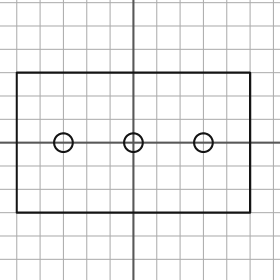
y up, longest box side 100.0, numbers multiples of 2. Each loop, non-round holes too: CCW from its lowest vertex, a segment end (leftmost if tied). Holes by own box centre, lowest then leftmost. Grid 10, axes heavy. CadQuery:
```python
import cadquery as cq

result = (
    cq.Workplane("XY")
    .moveTo(-50.0, -30.0)
    .lineTo(50.0, -30.0)
    .lineTo(50.0, 30.0)
    .lineTo(-50.0, 30.0)
    .close()
    .moveTo(-30.0, 0.0)
    .circle(4.0)
    .moveTo(0.0, 0.0)
    .circle(4.0)
    .moveTo(30.0, 0.0)
    .circle(4.0)
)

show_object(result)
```